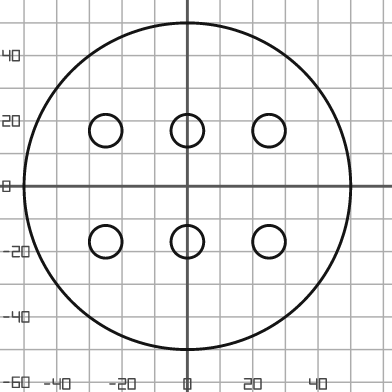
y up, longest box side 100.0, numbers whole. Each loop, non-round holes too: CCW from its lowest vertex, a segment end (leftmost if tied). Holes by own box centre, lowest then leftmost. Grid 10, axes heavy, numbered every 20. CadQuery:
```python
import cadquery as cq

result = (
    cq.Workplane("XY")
    .moveTo(0.0, 0.0)
    .circle(50.0)
    .moveTo(-25.0, -17.0)
    .circle(5.0)
    .moveTo(0.0, -17.0)
    .circle(5.0)
    .moveTo(25.0, -17.0)
    .circle(5.0)
    .moveTo(-25.0, 17.0)
    .circle(5.0)
    .moveTo(0.0, 17.0)
    .circle(5.0)
    .moveTo(25.0, 17.0)
    .circle(5.0)
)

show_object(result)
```